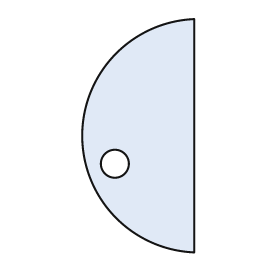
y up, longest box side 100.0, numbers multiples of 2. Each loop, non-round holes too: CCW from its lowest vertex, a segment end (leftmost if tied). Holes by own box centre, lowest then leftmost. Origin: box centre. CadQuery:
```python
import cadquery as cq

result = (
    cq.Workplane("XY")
    .moveTo(24.0, -50.0)
    .lineTo(24.0, 50.0)
    .threePointArc((-24.0, 0.0), (24.0, -50.0))
    .close()
    .moveTo(-10.0, -12.0)
    .circle(6.0)
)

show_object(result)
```